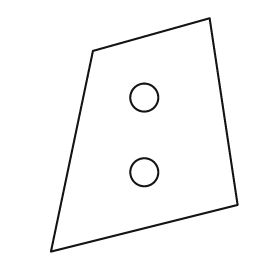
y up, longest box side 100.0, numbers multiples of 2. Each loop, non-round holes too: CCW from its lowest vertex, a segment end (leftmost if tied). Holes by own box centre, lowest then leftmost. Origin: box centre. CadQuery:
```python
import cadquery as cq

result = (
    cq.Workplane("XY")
    .moveTo(-40.0, -50.0)
    .lineTo(40.0, -30.0)
    .lineTo(28.0, 50.0)
    .lineTo(-22.0, 36.0)
    .close()
    .moveTo(0.0, -16.0)
    .circle(6.0)
    .moveTo(0.0, 16.0)
    .circle(6.0)
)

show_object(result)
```